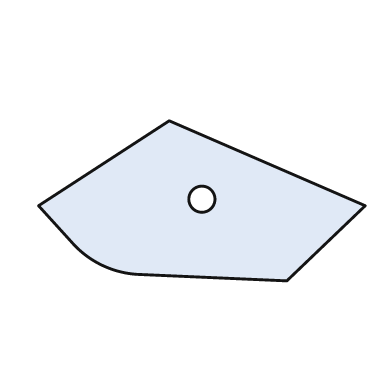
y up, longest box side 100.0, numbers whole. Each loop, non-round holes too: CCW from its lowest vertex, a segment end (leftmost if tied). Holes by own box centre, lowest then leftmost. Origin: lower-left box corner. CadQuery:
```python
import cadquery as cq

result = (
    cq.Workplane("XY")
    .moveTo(76.0, 0.0)
    .lineTo(100.0, 23.0)
    .lineTo(40.0, 49.0)
    .lineTo(0.0, 23.0)
    .lineTo(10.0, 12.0)
    .threePointArc((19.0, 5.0), (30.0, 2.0))
    .close()
    .moveTo(50.0, 25.0)
    .circle(4.0)
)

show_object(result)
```